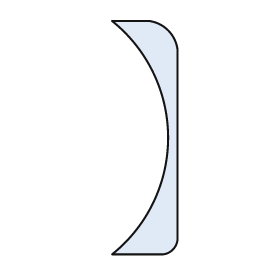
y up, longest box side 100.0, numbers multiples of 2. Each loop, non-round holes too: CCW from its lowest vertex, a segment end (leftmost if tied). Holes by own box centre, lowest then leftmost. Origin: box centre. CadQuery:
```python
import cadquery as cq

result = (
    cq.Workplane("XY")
    .moveTo(-14.0, -50.0)
    .lineTo(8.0, -50.0)
    .threePointArc((12.0, -48.0), (14.0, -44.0))
    .lineTo(14.0, 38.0)
    .threePointArc((10.0, 46.0), (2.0, 50.0))
    .lineTo(-14.0, 50.0)
    .threePointArc((10.0, 0.0), (-14.0, -50.0))
    .close()
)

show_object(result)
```